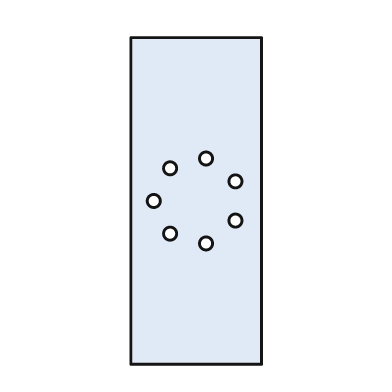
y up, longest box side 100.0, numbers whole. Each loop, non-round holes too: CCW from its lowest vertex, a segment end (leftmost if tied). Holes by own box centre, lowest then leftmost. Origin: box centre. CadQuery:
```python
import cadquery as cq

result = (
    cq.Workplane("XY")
    .moveTo(-20.0, -50.0)
    .lineTo(20.0, -50.0)
    .lineTo(20.0, 50.0)
    .lineTo(-20.0, 50.0)
    .close()
    .moveTo(3.0, -13.0)
    .circle(2.0)
    .moveTo(-8.0, -10.0)
    .circle(2.0)
    .moveTo(12.0, -6.0)
    .circle(2.0)
    .moveTo(-13.0, 0.0)
    .circle(2.0)
    .moveTo(12.0, 6.0)
    .circle(2.0)
    .moveTo(-8.0, 10.0)
    .circle(2.0)
    .moveTo(3.0, 13.0)
    .circle(2.0)
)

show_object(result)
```